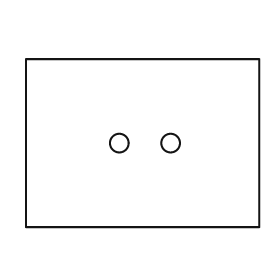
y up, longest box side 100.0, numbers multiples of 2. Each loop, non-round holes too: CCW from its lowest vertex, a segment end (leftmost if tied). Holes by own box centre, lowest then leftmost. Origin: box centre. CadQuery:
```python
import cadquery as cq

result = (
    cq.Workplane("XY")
    .moveTo(-50.0, -36.0)
    .lineTo(50.0, -36.0)
    .lineTo(50.0, 36.0)
    .lineTo(-50.0, 36.0)
    .close()
    .moveTo(-10.0, 0.0)
    .circle(4.0)
    .moveTo(12.0, 0.0)
    .circle(4.0)
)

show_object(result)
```